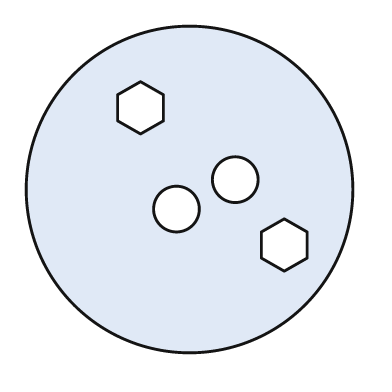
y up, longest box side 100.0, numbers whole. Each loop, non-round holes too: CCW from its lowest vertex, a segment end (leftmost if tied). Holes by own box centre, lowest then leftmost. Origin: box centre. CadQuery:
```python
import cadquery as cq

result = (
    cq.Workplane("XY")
    .moveTo(0.0, 0.0)
    .circle(50.0)
    .moveTo(29.0, -25.0)
    .lineTo(36.0, -21.0)
    .lineTo(36.0, -13.0)
    .lineTo(29.0, -9.0)
    .lineTo(22.0, -13.0)
    .lineTo(22.0, -21.0)
    .close()
    .moveTo(-4.0, -6.0)
    .circle(7.0)
    .moveTo(14.0, 3.0)
    .circle(7.0)
    .moveTo(-15.0, 17.0)
    .lineTo(-8.0, 21.0)
    .lineTo(-8.0, 29.0)
    .lineTo(-15.0, 33.0)
    .lineTo(-22.0, 29.0)
    .lineTo(-22.0, 21.0)
    .close()
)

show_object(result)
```